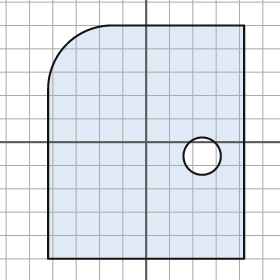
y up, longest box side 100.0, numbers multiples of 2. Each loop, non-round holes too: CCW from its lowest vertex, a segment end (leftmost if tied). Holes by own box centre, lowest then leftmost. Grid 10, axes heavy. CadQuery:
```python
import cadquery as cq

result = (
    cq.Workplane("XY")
    .moveTo(-42.0, -50.0)
    .lineTo(42.0, -50.0)
    .lineTo(42.0, 50.0)
    .lineTo(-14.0, 50.0)
    .threePointArc((-34.0, 42.0), (-42.0, 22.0))
    .close()
    .moveTo(24.0, -6.0)
    .circle(8.0)
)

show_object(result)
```